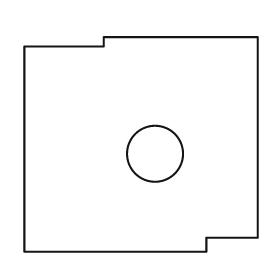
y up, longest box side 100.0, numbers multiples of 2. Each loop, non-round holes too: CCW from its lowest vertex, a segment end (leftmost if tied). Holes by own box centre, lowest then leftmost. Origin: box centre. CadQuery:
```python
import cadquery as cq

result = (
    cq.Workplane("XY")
    .moveTo(-50.0, -46.0)
    .lineTo(28.0, -46.0)
    .lineTo(28.0, -40.0)
    .lineTo(50.0, -40.0)
    .lineTo(50.0, 46.0)
    .lineTo(-16.0, 46.0)
    .lineTo(-16.0, 42.0)
    .lineTo(-50.0, 42.0)
    .close()
    .moveTo(6.0, -4.0)
    .circle(12.0)
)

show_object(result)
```